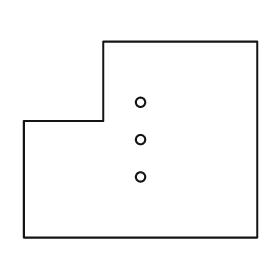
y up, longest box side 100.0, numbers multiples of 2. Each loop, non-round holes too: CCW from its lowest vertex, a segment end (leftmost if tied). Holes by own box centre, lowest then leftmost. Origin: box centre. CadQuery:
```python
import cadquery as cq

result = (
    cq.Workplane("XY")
    .moveTo(-50.0, -42.0)
    .lineTo(50.0, -42.0)
    .lineTo(50.0, 42.0)
    .lineTo(-16.0, 42.0)
    .lineTo(-16.0, 8.0)
    .lineTo(-50.0, 8.0)
    .close()
    .moveTo(0.0, -16.0)
    .circle(2.0)
    .moveTo(0.0, 0.0)
    .circle(2.0)
    .moveTo(0.0, 16.0)
    .circle(2.0)
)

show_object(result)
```